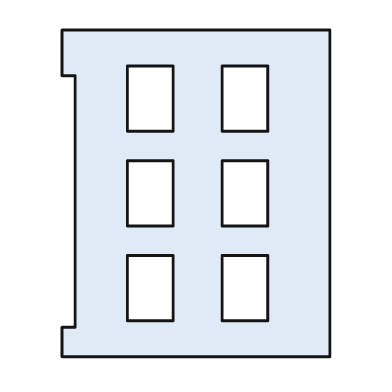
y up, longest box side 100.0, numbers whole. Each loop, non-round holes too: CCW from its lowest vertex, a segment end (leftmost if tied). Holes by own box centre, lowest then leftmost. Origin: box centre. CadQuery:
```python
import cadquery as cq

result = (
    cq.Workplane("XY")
    .moveTo(-41.0, -50.0)
    .lineTo(41.0, -50.0)
    .lineTo(41.0, 50.0)
    .lineTo(-41.0, 50.0)
    .lineTo(-41.0, 36.0)
    .lineTo(-37.0, 36.0)
    .lineTo(-37.0, -41.0)
    .lineTo(-41.0, -41.0)
    .close()
    .moveTo(-21.0, -39.0)
    .lineTo(-7.0, -39.0)
    .lineTo(-7.0, -19.0)
    .lineTo(-21.0, -19.0)
    .close()
    .moveTo(8.0, -39.0)
    .lineTo(22.0, -39.0)
    .lineTo(22.0, -19.0)
    .lineTo(8.0, -19.0)
    .close()
    .moveTo(-21.0, -10.0)
    .lineTo(-7.0, -10.0)
    .lineTo(-7.0, 10.0)
    .lineTo(-21.0, 10.0)
    .close()
    .moveTo(8.0, -10.0)
    .lineTo(22.0, -10.0)
    .lineTo(22.0, 10.0)
    .lineTo(8.0, 10.0)
    .close()
    .moveTo(-21.0, 19.0)
    .lineTo(-7.0, 19.0)
    .lineTo(-7.0, 39.0)
    .lineTo(-21.0, 39.0)
    .close()
    .moveTo(8.0, 19.0)
    .lineTo(22.0, 19.0)
    .lineTo(22.0, 39.0)
    .lineTo(8.0, 39.0)
    .close()
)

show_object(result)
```